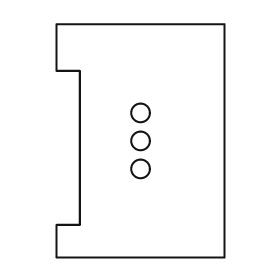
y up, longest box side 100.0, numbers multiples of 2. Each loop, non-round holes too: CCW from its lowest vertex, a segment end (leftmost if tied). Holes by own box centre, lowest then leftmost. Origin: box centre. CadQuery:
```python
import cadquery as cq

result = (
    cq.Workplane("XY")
    .moveTo(-36.0, -50.0)
    .lineTo(36.0, -50.0)
    .lineTo(36.0, 50.0)
    .lineTo(-36.0, 50.0)
    .lineTo(-36.0, 30.0)
    .lineTo(-26.0, 30.0)
    .lineTo(-26.0, -36.0)
    .lineTo(-36.0, -36.0)
    .close()
    .moveTo(0.0, -12.0)
    .circle(4.0)
    .moveTo(0.0, 0.0)
    .circle(4.0)
    .moveTo(0.0, 12.0)
    .circle(4.0)
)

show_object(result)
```